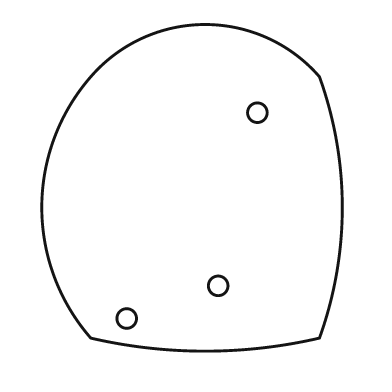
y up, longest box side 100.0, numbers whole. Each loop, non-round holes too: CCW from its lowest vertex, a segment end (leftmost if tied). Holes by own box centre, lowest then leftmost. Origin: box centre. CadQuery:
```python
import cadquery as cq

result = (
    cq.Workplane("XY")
    .moveTo(-31.0, -46.0)
    .threePointArc((4.0, -50.0), (39.0, -46.0))
    .threePointArc((46.0, -6.0), (39.0, 34.0))
    .threePointArc((4.0, 50.0), (-31.0, 34.0))
    .threePointArc((-46.0, -6.0), (-31.0, -46.0))
    .close()
    .moveTo(-20.0, -40.0)
    .circle(3.0)
    .moveTo(8.0, -30.0)
    .circle(3.0)
    .moveTo(20.0, 23.0)
    .circle(3.0)
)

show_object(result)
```